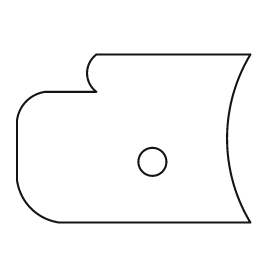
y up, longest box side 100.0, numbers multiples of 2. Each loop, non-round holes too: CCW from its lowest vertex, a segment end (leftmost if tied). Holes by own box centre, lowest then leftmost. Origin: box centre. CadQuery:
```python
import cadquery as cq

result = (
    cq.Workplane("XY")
    .moveTo(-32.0, -36.0)
    .lineTo(50.0, -36.0)
    .threePointArc((40.0, 0.0), (50.0, 36.0))
    .lineTo(-16.0, 36.0)
    .threePointArc((-20.0, 28.0), (-16.0, 20.0))
    .lineTo(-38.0, 20.0)
    .threePointArc((-46.0, 16.0), (-50.0, 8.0))
    .lineTo(-50.0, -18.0)
    .threePointArc((-44.0, -30.0), (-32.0, -36.0))
    .close()
    .moveTo(8.0, -10.0)
    .circle(6.0)
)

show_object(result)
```